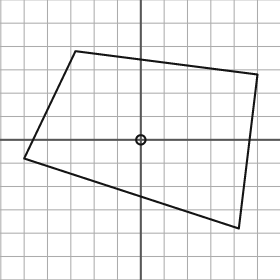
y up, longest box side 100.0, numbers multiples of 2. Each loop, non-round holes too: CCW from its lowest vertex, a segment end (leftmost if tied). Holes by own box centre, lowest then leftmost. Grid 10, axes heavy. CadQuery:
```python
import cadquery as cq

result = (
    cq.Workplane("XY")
    .moveTo(42.0, -38.0)
    .lineTo(50.0, 28.0)
    .lineTo(-28.0, 38.0)
    .lineTo(-50.0, -8.0)
    .close()
    .moveTo(0.0, 0.0)
    .circle(2.0)
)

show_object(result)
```